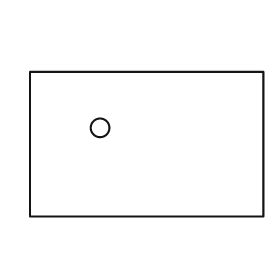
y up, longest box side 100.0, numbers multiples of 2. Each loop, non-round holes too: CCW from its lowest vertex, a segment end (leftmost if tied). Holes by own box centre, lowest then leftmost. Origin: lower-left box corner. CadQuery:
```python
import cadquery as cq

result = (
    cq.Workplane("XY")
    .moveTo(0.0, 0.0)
    .lineTo(100.0, 0.0)
    .lineTo(100.0, 62.0)
    .lineTo(0.0, 62.0)
    .close()
    .moveTo(30.0, 38.0)
    .circle(4.0)
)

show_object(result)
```